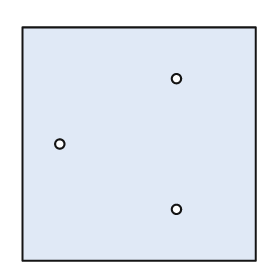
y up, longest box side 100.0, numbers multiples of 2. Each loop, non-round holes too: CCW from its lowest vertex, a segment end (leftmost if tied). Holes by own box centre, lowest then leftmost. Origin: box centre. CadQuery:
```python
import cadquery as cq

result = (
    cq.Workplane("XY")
    .moveTo(-50.0, -50.0)
    .lineTo(50.0, -50.0)
    .lineTo(50.0, 50.0)
    .lineTo(-50.0, 50.0)
    .close()
    .moveTo(16.0, -28.0)
    .circle(2.0)
    .moveTo(-34.0, 0.0)
    .circle(2.0)
    .moveTo(16.0, 28.0)
    .circle(2.0)
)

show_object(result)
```